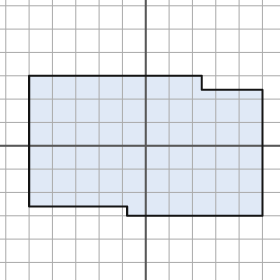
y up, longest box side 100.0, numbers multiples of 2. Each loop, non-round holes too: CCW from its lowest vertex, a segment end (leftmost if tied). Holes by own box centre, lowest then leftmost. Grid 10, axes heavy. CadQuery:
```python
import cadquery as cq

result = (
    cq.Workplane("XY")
    .moveTo(-8.0, -30.0)
    .lineTo(50.0, -30.0)
    .lineTo(50.0, 24.0)
    .lineTo(24.0, 24.0)
    .lineTo(24.0, 30.0)
    .lineTo(-50.0, 30.0)
    .lineTo(-50.0, -26.0)
    .lineTo(-8.0, -26.0)
    .close()
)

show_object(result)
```